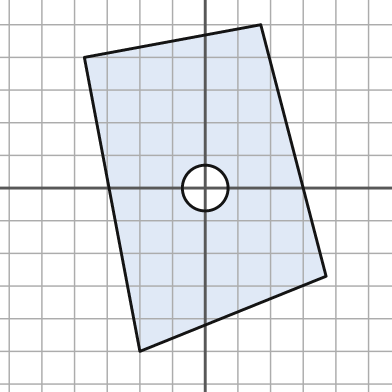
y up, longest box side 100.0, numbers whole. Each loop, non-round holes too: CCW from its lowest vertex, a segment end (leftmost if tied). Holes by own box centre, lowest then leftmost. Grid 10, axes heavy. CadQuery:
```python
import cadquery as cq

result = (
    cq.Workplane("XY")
    .moveTo(-20.0, -50.0)
    .lineTo(37.0, -27.0)
    .lineTo(17.0, 50.0)
    .lineTo(-37.0, 40.0)
    .close()
    .moveTo(0.0, 0.0)
    .circle(7.0)
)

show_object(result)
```